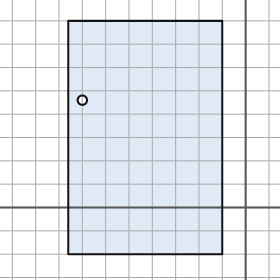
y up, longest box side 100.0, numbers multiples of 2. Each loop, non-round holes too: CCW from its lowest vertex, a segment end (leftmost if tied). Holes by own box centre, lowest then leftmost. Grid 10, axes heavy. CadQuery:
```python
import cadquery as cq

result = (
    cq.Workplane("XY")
    .moveTo(-76.0, -20.0)
    .lineTo(-10.0, -20.0)
    .lineTo(-10.0, 80.0)
    .lineTo(-76.0, 80.0)
    .close()
    .moveTo(-70.0, 46.0)
    .circle(2.0)
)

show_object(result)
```